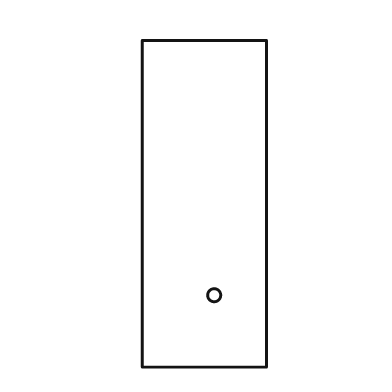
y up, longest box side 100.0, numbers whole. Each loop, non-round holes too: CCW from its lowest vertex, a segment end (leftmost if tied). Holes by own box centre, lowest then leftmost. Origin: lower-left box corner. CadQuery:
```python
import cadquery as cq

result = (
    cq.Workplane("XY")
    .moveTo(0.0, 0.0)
    .lineTo(38.0, 0.0)
    .lineTo(38.0, 100.0)
    .lineTo(0.0, 100.0)
    .close()
    .moveTo(22.0, 22.0)
    .circle(2.0)
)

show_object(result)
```